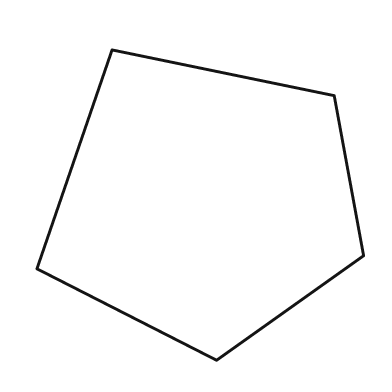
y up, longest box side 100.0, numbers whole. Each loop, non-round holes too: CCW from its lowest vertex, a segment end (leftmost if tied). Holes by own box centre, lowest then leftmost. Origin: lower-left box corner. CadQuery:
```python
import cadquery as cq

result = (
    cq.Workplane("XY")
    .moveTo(55.0, 0.0)
    .lineTo(100.0, 32.0)
    .lineTo(91.0, 81.0)
    .lineTo(23.0, 95.0)
    .lineTo(0.0, 28.0)
    .close()
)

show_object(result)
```